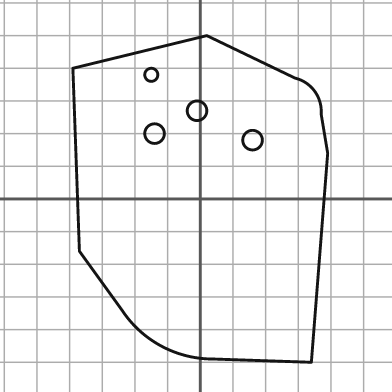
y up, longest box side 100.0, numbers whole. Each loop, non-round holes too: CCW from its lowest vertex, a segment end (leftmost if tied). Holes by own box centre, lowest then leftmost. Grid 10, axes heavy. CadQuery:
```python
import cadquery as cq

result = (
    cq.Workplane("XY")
    .moveTo(34.0, -50.0)
    .lineTo(39.0, 14.0)
    .lineTo(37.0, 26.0)
    .threePointArc((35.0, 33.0), (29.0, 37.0))
    .lineTo(2.0, 50.0)
    .lineTo(-39.0, 40.0)
    .lineTo(-37.0, -16.0)
    .lineTo(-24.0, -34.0)
    .threePointArc((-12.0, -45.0), (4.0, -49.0))
    .close()
    .moveTo(16.0, 18.0)
    .circle(3.0)
    .moveTo(-14.0, 20.0)
    .circle(3.0)
    .moveTo(-1.0, 27.0)
    .circle(3.0)
    .moveTo(-15.0, 38.0)
    .circle(2.0)
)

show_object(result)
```